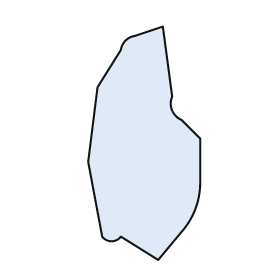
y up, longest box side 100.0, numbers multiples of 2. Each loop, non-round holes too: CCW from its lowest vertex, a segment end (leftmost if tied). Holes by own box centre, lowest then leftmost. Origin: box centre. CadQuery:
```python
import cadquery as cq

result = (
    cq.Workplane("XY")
    .moveTo(6.0, -50.0)
    .lineTo(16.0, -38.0)
    .threePointArc((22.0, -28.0), (24.0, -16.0))
    .lineTo(24.0, 2.0)
    .lineTo(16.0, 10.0)
    .threePointArc((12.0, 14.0), (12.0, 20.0))
    .lineTo(8.0, 50.0)
    .lineTo(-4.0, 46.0)
    .threePointArc((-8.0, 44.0), (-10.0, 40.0))
    .lineTo(-20.0, 24.0)
    .lineTo(-24.0, -8.0)
    .lineTo(-18.0, -40.0)
    .threePointArc((-14.0, -42.0), (-10.0, -40.0))
    .close()
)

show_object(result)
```